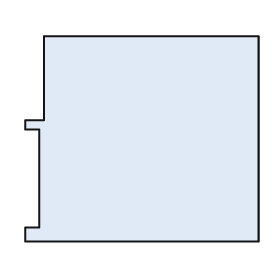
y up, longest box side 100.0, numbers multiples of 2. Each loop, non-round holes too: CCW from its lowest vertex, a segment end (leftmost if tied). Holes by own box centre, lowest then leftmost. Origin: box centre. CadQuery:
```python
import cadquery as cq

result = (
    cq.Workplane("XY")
    .moveTo(-50.0, -44.0)
    .lineTo(50.0, -44.0)
    .lineTo(50.0, 44.0)
    .lineTo(-42.0, 44.0)
    .lineTo(-42.0, 8.0)
    .lineTo(-50.0, 8.0)
    .lineTo(-50.0, 4.0)
    .lineTo(-44.0, 4.0)
    .lineTo(-44.0, -38.0)
    .lineTo(-50.0, -38.0)
    .close()
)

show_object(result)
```